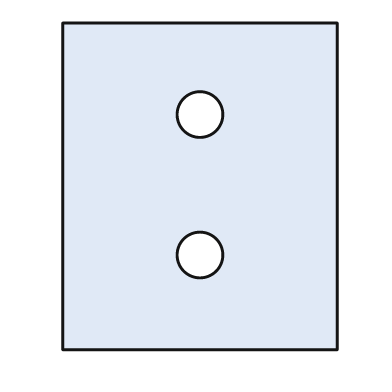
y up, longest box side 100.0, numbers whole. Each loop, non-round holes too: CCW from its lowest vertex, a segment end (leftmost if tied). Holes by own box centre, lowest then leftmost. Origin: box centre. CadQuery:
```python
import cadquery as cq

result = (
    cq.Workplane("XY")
    .moveTo(-42.0, -50.0)
    .lineTo(42.0, -50.0)
    .lineTo(42.0, 50.0)
    .lineTo(-42.0, 50.0)
    .close()
    .moveTo(0.0, -21.0)
    .circle(7.0)
    .moveTo(0.0, 22.0)
    .circle(7.0)
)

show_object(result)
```